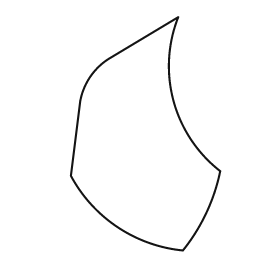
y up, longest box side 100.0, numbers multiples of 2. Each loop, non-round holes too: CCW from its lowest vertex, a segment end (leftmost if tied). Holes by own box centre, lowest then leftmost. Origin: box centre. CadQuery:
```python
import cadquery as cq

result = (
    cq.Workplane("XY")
    .moveTo(16.0, -50.0)
    .threePointArc((26.0, -34.0), (32.0, -16.0))
    .threePointArc((12.0, 14.0), (14.0, 50.0))
    .lineTo(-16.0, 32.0)
    .threePointArc((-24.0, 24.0), (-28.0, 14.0))
    .lineTo(-32.0, -18.0)
    .threePointArc((-12.0, -40.0), (16.0, -50.0))
    .close()
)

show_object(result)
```